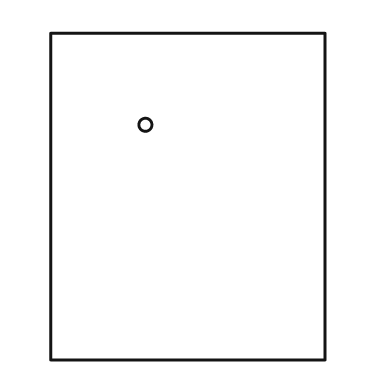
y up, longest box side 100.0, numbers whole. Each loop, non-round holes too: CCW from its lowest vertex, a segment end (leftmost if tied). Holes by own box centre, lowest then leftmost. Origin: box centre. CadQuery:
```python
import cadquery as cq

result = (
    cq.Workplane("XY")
    .moveTo(-42.0, -50.0)
    .lineTo(42.0, -50.0)
    .lineTo(42.0, 50.0)
    .lineTo(-42.0, 50.0)
    .close()
    .moveTo(-13.0, 22.0)
    .circle(2.0)
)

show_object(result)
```